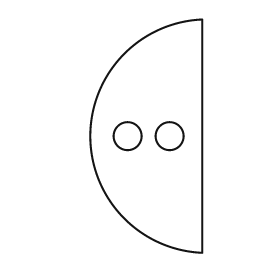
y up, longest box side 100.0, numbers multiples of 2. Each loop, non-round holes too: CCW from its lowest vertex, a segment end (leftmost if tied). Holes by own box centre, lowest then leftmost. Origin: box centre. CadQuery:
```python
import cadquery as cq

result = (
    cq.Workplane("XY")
    .moveTo(24.0, -50.0)
    .lineTo(24.0, 50.0)
    .threePointArc((-24.0, 0.0), (24.0, -50.0))
    .close()
    .moveTo(-8.0, 0.0)
    .circle(6.0)
    .moveTo(10.0, 0.0)
    .circle(6.0)
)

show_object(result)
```